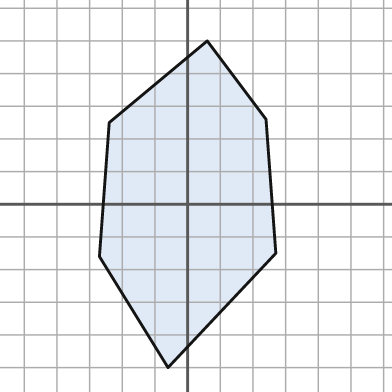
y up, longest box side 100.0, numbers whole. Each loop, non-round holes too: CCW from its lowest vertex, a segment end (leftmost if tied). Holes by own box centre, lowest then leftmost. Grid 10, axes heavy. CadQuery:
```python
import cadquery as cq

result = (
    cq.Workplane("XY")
    .moveTo(-6.0, -50.0)
    .lineTo(27.0, -15.0)
    .lineTo(24.0, 26.0)
    .lineTo(6.0, 50.0)
    .lineTo(-24.0, 25.0)
    .lineTo(-27.0, -16.0)
    .close()
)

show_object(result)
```